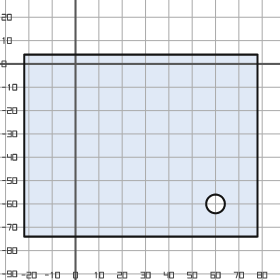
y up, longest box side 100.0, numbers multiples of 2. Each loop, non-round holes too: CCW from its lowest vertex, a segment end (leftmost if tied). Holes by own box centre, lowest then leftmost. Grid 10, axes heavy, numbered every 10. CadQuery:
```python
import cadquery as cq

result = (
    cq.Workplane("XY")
    .moveTo(-22.0, -74.0)
    .lineTo(78.0, -74.0)
    .lineTo(78.0, 4.0)
    .lineTo(-22.0, 4.0)
    .close()
    .moveTo(60.0, -60.0)
    .circle(4.0)
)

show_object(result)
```